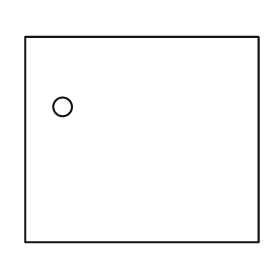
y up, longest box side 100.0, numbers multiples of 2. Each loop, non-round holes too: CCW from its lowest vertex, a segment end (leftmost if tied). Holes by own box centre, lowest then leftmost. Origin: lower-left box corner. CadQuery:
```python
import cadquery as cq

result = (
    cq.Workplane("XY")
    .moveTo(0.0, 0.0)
    .lineTo(100.0, 0.0)
    .lineTo(100.0, 88.0)
    .lineTo(0.0, 88.0)
    .close()
    .moveTo(16.0, 58.0)
    .circle(4.0)
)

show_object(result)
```